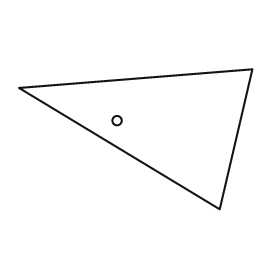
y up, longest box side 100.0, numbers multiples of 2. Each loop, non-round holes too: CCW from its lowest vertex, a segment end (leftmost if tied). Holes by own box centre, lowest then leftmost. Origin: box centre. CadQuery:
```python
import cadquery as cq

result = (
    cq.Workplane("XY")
    .moveTo(36.0, -30.0)
    .lineTo(50.0, 30.0)
    .lineTo(-50.0, 22.0)
    .close()
    .moveTo(-8.0, 8.0)
    .circle(2.0)
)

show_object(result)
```